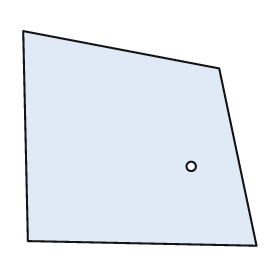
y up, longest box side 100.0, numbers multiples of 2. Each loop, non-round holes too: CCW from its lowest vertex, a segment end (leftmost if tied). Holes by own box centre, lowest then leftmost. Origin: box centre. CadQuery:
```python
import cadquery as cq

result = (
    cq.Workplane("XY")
    .moveTo(50.0, -46.0)
    .lineTo(34.0, 30.0)
    .lineTo(-50.0, 46.0)
    .lineTo(-48.0, -44.0)
    .close()
    .moveTo(22.0, -12.0)
    .circle(2.0)
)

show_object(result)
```